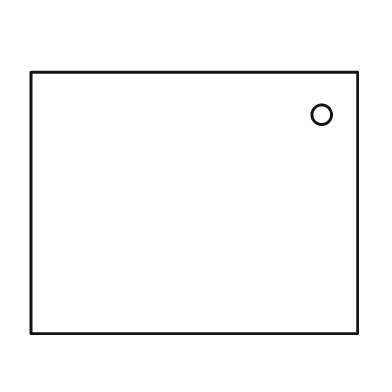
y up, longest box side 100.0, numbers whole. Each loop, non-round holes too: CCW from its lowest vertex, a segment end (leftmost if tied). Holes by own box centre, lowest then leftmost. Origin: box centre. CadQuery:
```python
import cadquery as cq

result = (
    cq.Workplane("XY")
    .moveTo(-50.0, -40.0)
    .lineTo(50.0, -40.0)
    .lineTo(50.0, 40.0)
    .lineTo(-50.0, 40.0)
    .close()
    .moveTo(39.0, 27.0)
    .circle(3.0)
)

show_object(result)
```